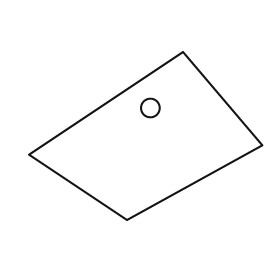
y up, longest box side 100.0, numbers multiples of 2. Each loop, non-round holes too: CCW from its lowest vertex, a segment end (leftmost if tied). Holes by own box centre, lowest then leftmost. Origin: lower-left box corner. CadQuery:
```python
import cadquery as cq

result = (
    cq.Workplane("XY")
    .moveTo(42.0, 0.0)
    .lineTo(100.0, 32.0)
    .lineTo(66.0, 72.0)
    .lineTo(0.0, 28.0)
    .close()
    .moveTo(52.0, 48.0)
    .circle(4.0)
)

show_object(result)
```